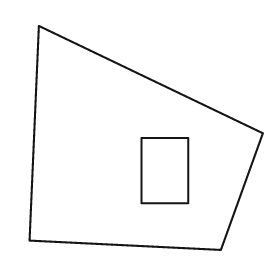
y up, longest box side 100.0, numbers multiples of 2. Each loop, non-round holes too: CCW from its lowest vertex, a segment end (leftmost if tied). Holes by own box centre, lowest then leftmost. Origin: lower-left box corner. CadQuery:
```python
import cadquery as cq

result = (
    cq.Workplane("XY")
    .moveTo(82.0, 0.0)
    .lineTo(100.0, 50.0)
    .lineTo(4.0, 96.0)
    .lineTo(0.0, 4.0)
    .close()
    .moveTo(48.0, 20.0)
    .lineTo(68.0, 20.0)
    .lineTo(68.0, 48.0)
    .lineTo(48.0, 48.0)
    .close()
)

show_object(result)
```